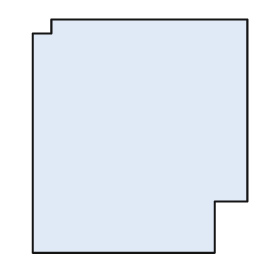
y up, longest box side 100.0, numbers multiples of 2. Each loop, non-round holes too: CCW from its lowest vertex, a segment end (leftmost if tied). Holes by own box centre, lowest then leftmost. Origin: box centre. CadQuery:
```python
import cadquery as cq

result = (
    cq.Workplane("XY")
    .moveTo(-46.0, -50.0)
    .lineTo(32.0, -50.0)
    .lineTo(32.0, -28.0)
    .lineTo(46.0, -28.0)
    .lineTo(46.0, 50.0)
    .lineTo(-38.0, 50.0)
    .lineTo(-38.0, 44.0)
    .lineTo(-46.0, 44.0)
    .close()
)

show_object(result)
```